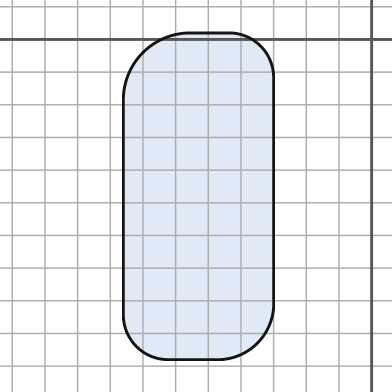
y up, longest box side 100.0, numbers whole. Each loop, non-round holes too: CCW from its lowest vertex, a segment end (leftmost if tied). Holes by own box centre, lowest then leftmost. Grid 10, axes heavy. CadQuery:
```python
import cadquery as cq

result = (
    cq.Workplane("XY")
    .moveTo(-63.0, -98.0)
    .lineTo(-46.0, -98.0)
    .threePointArc((-35.0, -93.0), (-30.0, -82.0))
    .lineTo(-30.0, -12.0)
    .threePointArc((-34.0, -2.0), (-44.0, 2.0))
    .lineTo(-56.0, 2.0)
    .threePointArc((-70.0, -4.0), (-76.0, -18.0))
    .lineTo(-76.0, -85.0)
    .threePointArc((-72.0, -94.0), (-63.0, -98.0))
    .close()
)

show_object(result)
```